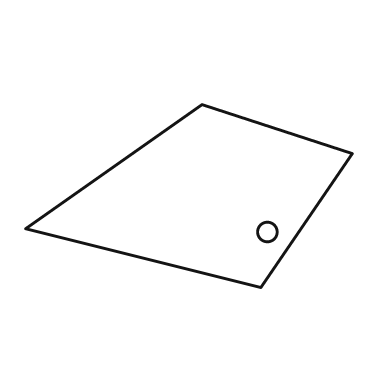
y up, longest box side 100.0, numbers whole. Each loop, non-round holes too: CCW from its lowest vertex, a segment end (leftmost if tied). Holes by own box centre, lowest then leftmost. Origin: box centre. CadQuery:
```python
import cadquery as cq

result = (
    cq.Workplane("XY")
    .moveTo(22.0, -28.0)
    .lineTo(50.0, 13.0)
    .lineTo(4.0, 28.0)
    .lineTo(-50.0, -10.0)
    .close()
    .moveTo(24.0, -11.0)
    .circle(3.0)
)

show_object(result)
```